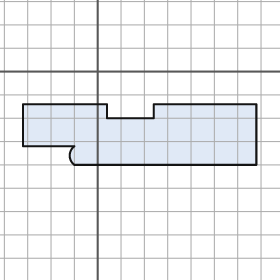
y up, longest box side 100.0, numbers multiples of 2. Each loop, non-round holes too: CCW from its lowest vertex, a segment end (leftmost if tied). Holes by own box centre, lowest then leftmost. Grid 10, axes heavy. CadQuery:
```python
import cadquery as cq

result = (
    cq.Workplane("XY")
    .moveTo(-10.0, -40.0)
    .lineTo(68.0, -40.0)
    .lineTo(68.0, -14.0)
    .lineTo(24.0, -14.0)
    .lineTo(24.0, -20.0)
    .lineTo(4.0, -20.0)
    .lineTo(4.0, -14.0)
    .lineTo(-32.0, -14.0)
    .lineTo(-32.0, -32.0)
    .lineTo(-10.0, -32.0)
    .threePointArc((-12.0, -36.0), (-10.0, -40.0))
    .close()
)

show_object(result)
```